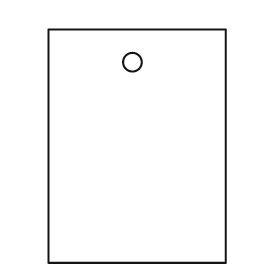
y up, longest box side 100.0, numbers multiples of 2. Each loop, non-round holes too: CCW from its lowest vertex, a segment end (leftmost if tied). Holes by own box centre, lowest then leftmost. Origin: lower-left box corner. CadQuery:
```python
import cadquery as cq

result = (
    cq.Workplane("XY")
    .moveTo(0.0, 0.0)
    .lineTo(76.0, 0.0)
    .lineTo(76.0, 100.0)
    .lineTo(0.0, 100.0)
    .close()
    .moveTo(36.0, 86.0)
    .circle(4.0)
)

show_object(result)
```